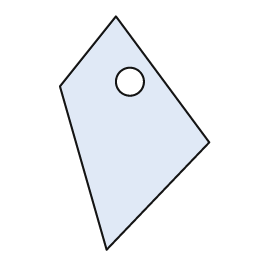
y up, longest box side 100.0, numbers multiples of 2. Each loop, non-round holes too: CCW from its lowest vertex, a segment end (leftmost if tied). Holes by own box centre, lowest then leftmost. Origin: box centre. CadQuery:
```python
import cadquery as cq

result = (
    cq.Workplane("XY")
    .moveTo(-12.0, -50.0)
    .lineTo(32.0, -4.0)
    .lineTo(-8.0, 50.0)
    .lineTo(-32.0, 20.0)
    .close()
    .moveTo(-2.0, 22.0)
    .circle(6.0)
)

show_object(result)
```